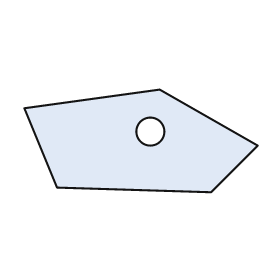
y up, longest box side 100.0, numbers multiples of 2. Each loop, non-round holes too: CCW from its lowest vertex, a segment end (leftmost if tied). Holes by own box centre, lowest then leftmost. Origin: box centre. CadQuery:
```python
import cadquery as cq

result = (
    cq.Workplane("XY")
    .moveTo(30.0, -22.0)
    .lineTo(50.0, -2.0)
    .lineTo(8.0, 22.0)
    .lineTo(-50.0, 14.0)
    .lineTo(-36.0, -20.0)
    .close()
    .moveTo(4.0, 4.0)
    .circle(6.0)
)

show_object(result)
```